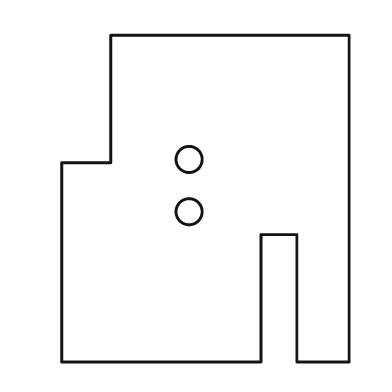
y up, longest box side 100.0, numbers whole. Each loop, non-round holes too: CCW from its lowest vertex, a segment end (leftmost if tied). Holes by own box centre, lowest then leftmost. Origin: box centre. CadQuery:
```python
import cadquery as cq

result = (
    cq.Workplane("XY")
    .moveTo(-44.0, -50.0)
    .lineTo(17.0, -50.0)
    .lineTo(17.0, -11.0)
    .lineTo(28.0, -11.0)
    .lineTo(28.0, -50.0)
    .lineTo(44.0, -50.0)
    .lineTo(44.0, 50.0)
    .lineTo(-29.0, 50.0)
    .lineTo(-29.0, 11.0)
    .lineTo(-44.0, 11.0)
    .close()
    .moveTo(-5.0, -4.0)
    .circle(4.0)
    .moveTo(-5.0, 12.0)
    .circle(4.0)
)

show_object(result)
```